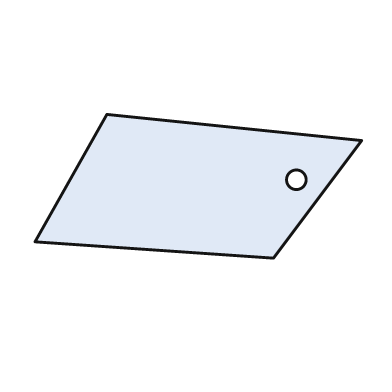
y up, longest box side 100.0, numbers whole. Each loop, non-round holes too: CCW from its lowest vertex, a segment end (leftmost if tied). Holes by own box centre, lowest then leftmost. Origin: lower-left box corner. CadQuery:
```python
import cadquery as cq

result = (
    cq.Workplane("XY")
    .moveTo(73.0, 0.0)
    .lineTo(100.0, 36.0)
    .lineTo(22.0, 44.0)
    .lineTo(0.0, 5.0)
    .close()
    .moveTo(80.0, 24.0)
    .circle(3.0)
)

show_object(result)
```